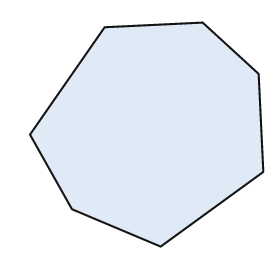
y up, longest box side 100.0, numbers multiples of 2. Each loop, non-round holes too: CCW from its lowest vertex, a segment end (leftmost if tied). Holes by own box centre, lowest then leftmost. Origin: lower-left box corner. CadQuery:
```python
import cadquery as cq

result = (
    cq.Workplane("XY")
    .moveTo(56.0, 0.0)
    .lineTo(100.0, 32.0)
    .lineTo(98.0, 74.0)
    .lineTo(74.0, 96.0)
    .lineTo(32.0, 94.0)
    .lineTo(0.0, 48.0)
    .lineTo(18.0, 16.0)
    .close()
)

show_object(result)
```